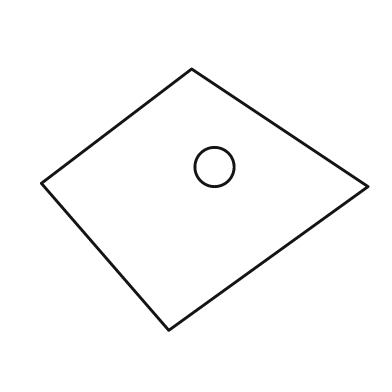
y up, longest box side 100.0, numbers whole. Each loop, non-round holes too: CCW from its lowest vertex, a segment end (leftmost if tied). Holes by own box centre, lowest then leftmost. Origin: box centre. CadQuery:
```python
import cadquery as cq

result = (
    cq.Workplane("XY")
    .moveTo(-11.0, -40.0)
    .lineTo(50.0, 4.0)
    .lineTo(-4.0, 40.0)
    .lineTo(-50.0, 5.0)
    .close()
    .moveTo(3.0, 10.0)
    .circle(6.0)
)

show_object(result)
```